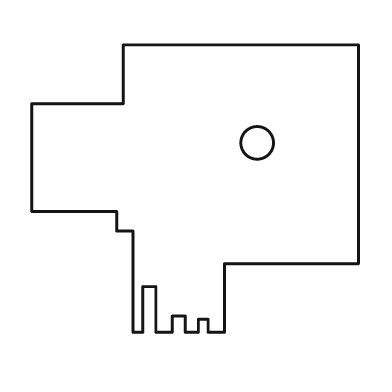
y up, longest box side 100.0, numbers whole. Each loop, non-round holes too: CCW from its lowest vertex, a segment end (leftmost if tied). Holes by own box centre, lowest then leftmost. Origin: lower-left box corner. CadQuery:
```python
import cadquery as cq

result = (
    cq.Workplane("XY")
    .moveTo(31.0, 0.0)
    .lineTo(34.0, 0.0)
    .lineTo(34.0, 14.0)
    .lineTo(38.0, 14.0)
    .lineTo(38.0, 0.0)
    .lineTo(43.0, 0.0)
    .lineTo(43.0, 5.0)
    .lineTo(47.0, 5.0)
    .lineTo(47.0, 0.0)
    .lineTo(51.0, 0.0)
    .lineTo(51.0, 4.0)
    .lineTo(54.0, 4.0)
    .lineTo(54.0, 0.0)
    .lineTo(59.0, 0.0)
    .lineTo(59.0, 21.0)
    .lineTo(100.0, 21.0)
    .lineTo(100.0, 88.0)
    .lineTo(28.0, 88.0)
    .lineTo(28.0, 70.0)
    .lineTo(0.0, 70.0)
    .lineTo(0.0, 37.0)
    .lineTo(26.0, 37.0)
    .lineTo(26.0, 31.0)
    .lineTo(31.0, 31.0)
    .close()
    .moveTo(69.0, 58.0)
    .circle(5.0)
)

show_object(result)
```